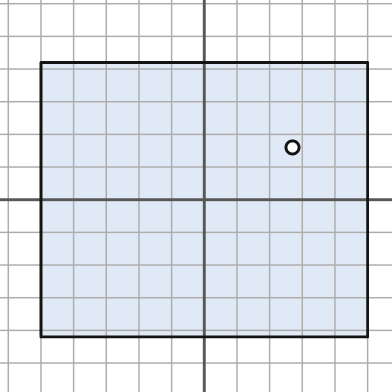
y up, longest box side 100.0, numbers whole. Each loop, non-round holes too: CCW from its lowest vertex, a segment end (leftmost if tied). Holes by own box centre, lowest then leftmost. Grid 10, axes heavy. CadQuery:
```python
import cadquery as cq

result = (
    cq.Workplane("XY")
    .moveTo(-50.0, -42.0)
    .lineTo(50.0, -42.0)
    .lineTo(50.0, 42.0)
    .lineTo(-50.0, 42.0)
    .close()
    .moveTo(27.0, 16.0)
    .circle(2.0)
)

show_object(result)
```